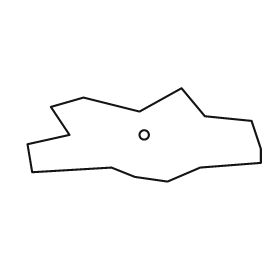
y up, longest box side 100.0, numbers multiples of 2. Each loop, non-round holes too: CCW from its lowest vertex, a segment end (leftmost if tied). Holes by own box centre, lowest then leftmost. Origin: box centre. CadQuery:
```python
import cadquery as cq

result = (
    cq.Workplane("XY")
    .moveTo(10.0, -20.0)
    .lineTo(24.0, -14.0)
    .lineTo(50.0, -12.0)
    .lineTo(50.0, -6.0)
    .lineTo(46.0, 6.0)
    .lineTo(26.0, 8.0)
    .lineTo(16.0, 20.0)
    .lineTo(-2.0, 10.0)
    .lineTo(-26.0, 16.0)
    .lineTo(-40.0, 12.0)
    .lineTo(-32.0, 0.0)
    .lineTo(-50.0, -4.0)
    .lineTo(-48.0, -16.0)
    .lineTo(-14.0, -14.0)
    .lineTo(-4.0, -18.0)
    .close()
    .moveTo(0.0, 0.0)
    .circle(2.0)
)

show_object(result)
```